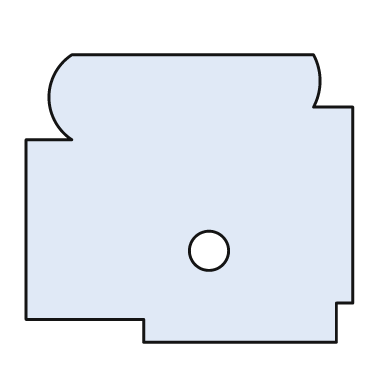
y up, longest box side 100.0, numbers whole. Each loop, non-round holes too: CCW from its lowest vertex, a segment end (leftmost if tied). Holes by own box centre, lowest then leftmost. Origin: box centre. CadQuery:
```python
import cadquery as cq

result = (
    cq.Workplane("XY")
    .moveTo(-14.0, -44.0)
    .lineTo(45.0, -44.0)
    .lineTo(45.0, -32.0)
    .lineTo(50.0, -32.0)
    .lineTo(50.0, 28.0)
    .lineTo(38.0, 28.0)
    .threePointArc((40.0, 36.0), (38.0, 44.0))
    .lineTo(-36.0, 44.0)
    .threePointArc((-43.0, 31.0), (-36.0, 18.0))
    .lineTo(-50.0, 18.0)
    .lineTo(-50.0, -37.0)
    .lineTo(-14.0, -37.0)
    .close()
    .moveTo(6.0, -16.0)
    .circle(6.0)
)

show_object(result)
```